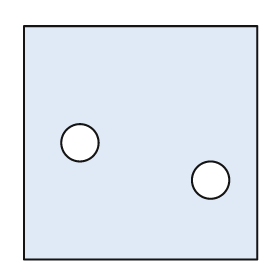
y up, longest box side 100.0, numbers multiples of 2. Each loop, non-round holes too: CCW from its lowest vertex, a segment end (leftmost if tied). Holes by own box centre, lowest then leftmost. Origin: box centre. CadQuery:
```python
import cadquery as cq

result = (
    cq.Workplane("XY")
    .moveTo(-50.0, -50.0)
    .lineTo(50.0, -50.0)
    .lineTo(50.0, 50.0)
    .lineTo(-50.0, 50.0)
    .close()
    .moveTo(30.0, -16.0)
    .circle(8.0)
    .moveTo(-26.0, 0.0)
    .circle(8.0)
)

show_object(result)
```